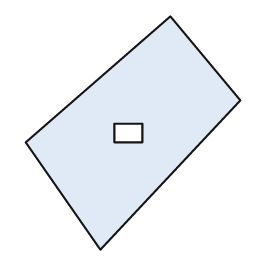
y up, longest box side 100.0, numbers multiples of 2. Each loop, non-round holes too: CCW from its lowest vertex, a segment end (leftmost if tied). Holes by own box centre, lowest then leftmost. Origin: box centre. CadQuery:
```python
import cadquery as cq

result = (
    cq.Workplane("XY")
    .moveTo(-14.0, -50.0)
    .lineTo(46.0, 14.0)
    .lineTo(16.0, 50.0)
    .lineTo(-46.0, -4.0)
    .close()
    .moveTo(-8.0, -4.0)
    .lineTo(4.0, -4.0)
    .lineTo(4.0, 4.0)
    .lineTo(-8.0, 4.0)
    .close()
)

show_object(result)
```